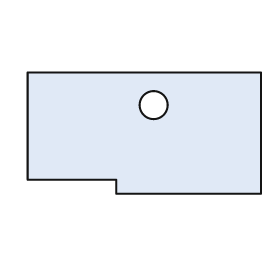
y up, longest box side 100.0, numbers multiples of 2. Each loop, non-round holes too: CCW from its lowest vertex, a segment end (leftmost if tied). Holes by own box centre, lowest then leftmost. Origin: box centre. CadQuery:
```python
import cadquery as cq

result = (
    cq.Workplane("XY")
    .moveTo(-12.0, -26.0)
    .lineTo(50.0, -26.0)
    .lineTo(50.0, 26.0)
    .lineTo(-50.0, 26.0)
    .lineTo(-50.0, -20.0)
    .lineTo(-12.0, -20.0)
    .close()
    .moveTo(4.0, 12.0)
    .circle(6.0)
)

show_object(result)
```